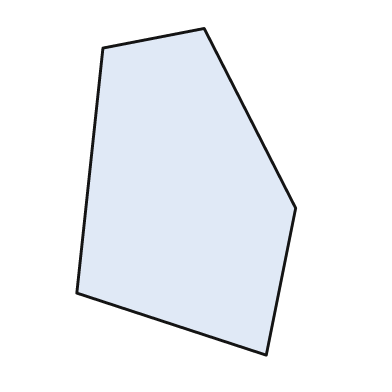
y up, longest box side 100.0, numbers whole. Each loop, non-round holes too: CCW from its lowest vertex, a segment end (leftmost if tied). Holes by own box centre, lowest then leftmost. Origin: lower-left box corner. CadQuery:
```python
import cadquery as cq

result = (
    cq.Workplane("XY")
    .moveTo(58.0, 0.0)
    .lineTo(67.0, 45.0)
    .lineTo(39.0, 100.0)
    .lineTo(8.0, 94.0)
    .lineTo(0.0, 19.0)
    .close()
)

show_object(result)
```